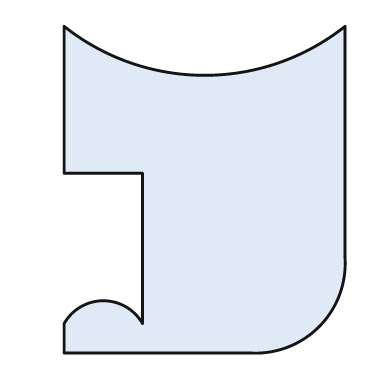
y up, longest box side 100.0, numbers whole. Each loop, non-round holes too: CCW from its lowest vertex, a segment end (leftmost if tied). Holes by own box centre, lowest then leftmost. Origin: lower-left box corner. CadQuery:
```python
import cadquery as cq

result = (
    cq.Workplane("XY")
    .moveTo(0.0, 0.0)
    .lineTo(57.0, 0.0)
    .threePointArc((78.0, 8.0), (86.0, 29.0))
    .lineTo(86.0, 100.0)
    .threePointArc((43.0, 85.0), (0.0, 100.0))
    .lineTo(0.0, 55.0)
    .lineTo(24.0, 55.0)
    .lineTo(24.0, 9.0)
    .threePointArc((12.0, 16.0), (0.0, 9.0))
    .close()
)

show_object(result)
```